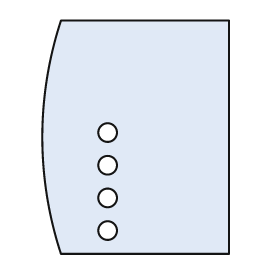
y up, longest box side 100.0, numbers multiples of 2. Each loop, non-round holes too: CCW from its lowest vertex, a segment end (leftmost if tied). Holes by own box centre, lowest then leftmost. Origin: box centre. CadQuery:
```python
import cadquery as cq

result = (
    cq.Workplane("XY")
    .moveTo(-32.0, -50.0)
    .lineTo(40.0, -50.0)
    .lineTo(40.0, 50.0)
    .lineTo(-32.0, 50.0)
    .threePointArc((-40.0, 0.0), (-32.0, -50.0))
    .close()
    .moveTo(-12.0, -40.0)
    .circle(4.0)
    .moveTo(-12.0, -26.0)
    .circle(4.0)
    .moveTo(-12.0, -12.0)
    .circle(4.0)
    .moveTo(-12.0, 2.0)
    .circle(4.0)
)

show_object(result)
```